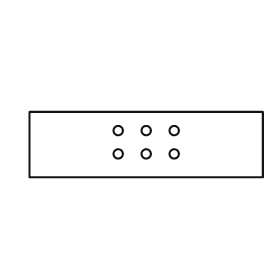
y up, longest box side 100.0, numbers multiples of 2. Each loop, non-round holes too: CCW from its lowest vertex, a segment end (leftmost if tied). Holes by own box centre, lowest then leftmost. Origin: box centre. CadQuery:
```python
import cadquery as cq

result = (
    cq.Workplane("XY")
    .moveTo(-50.0, -14.0)
    .lineTo(50.0, -14.0)
    .lineTo(50.0, 14.0)
    .lineTo(-50.0, 14.0)
    .close()
    .moveTo(-12.0, -4.0)
    .circle(2.0)
    .moveTo(0.0, -4.0)
    .circle(2.0)
    .moveTo(12.0, -4.0)
    .circle(2.0)
    .moveTo(-12.0, 6.0)
    .circle(2.0)
    .moveTo(0.0, 6.0)
    .circle(2.0)
    .moveTo(12.0, 6.0)
    .circle(2.0)
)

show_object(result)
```